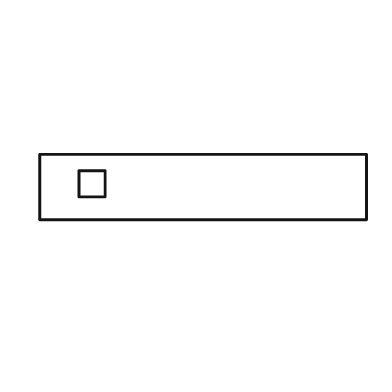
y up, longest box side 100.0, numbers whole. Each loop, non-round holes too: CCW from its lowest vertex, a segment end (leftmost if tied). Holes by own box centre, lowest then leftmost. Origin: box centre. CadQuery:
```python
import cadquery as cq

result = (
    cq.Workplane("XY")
    .moveTo(-50.0, -10.0)
    .lineTo(50.0, -10.0)
    .lineTo(50.0, 10.0)
    .lineTo(-50.0, 10.0)
    .close()
    .moveTo(-38.0, -3.0)
    .lineTo(-30.0, -3.0)
    .lineTo(-30.0, 5.0)
    .lineTo(-38.0, 5.0)
    .close()
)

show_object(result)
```